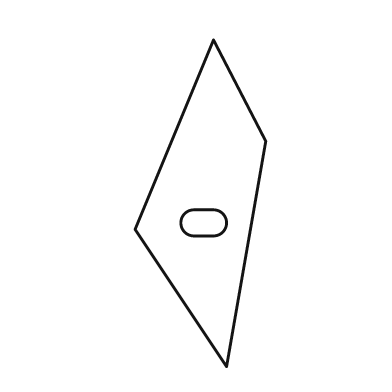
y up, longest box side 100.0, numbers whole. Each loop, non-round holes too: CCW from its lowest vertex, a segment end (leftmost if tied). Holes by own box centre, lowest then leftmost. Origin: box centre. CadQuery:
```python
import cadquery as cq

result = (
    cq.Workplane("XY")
    .moveTo(8.0, -50.0)
    .lineTo(20.0, 19.0)
    .lineTo(4.0, 50.0)
    .lineTo(-20.0, -8.0)
    .close()
    .moveTo(-2.0, -10.0)
    .lineTo(4.0, -10.0)
    .threePointArc((8.0, -6.0), (4.0, -2.0))
    .lineTo(-2.0, -2.0)
    .threePointArc((-6.0, -6.0), (-2.0, -10.0))
    .close()
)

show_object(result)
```